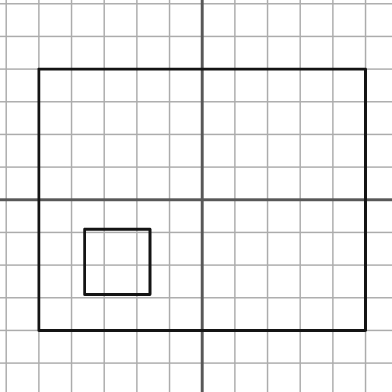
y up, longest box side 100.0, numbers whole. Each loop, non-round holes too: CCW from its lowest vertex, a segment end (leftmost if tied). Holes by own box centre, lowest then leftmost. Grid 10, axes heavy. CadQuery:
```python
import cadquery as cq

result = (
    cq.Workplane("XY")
    .moveTo(-50.0, -40.0)
    .lineTo(50.0, -40.0)
    .lineTo(50.0, 40.0)
    .lineTo(-50.0, 40.0)
    .close()
    .moveTo(-36.0, -29.0)
    .lineTo(-16.0, -29.0)
    .lineTo(-16.0, -9.0)
    .lineTo(-36.0, -9.0)
    .close()
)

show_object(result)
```